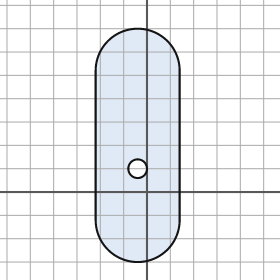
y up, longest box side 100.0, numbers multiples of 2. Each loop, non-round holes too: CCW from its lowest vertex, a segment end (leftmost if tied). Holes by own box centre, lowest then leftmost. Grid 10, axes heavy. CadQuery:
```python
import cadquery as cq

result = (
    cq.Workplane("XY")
    .moveTo(-22.0, -12.0)
    .threePointArc((-4.0, -30.0), (14.0, -12.0))
    .lineTo(14.0, 52.0)
    .threePointArc((-4.0, 70.0), (-22.0, 52.0))
    .close()
    .moveTo(-4.0, 10.0)
    .circle(4.0)
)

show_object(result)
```